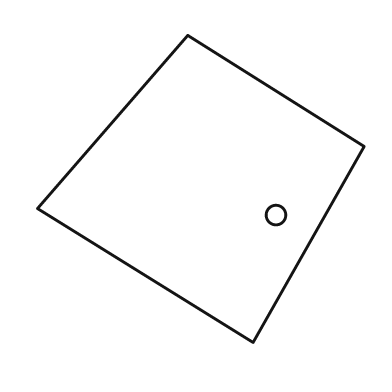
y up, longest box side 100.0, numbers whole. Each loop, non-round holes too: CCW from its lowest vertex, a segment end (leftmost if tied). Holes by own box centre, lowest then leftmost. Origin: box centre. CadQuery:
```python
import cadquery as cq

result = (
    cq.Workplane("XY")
    .moveTo(16.0, -47.0)
    .lineTo(50.0, 13.0)
    .lineTo(-4.0, 47.0)
    .lineTo(-50.0, -6.0)
    .close()
    .moveTo(23.0, -8.0)
    .circle(3.0)
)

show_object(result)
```